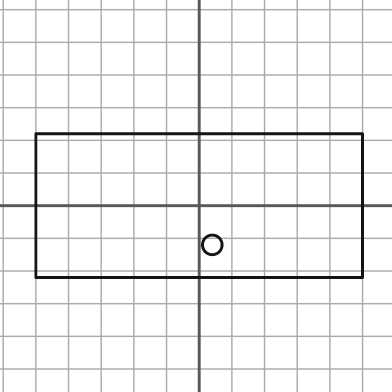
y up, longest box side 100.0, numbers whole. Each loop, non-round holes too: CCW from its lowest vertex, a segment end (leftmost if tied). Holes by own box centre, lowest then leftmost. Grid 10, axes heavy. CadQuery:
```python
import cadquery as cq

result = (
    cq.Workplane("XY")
    .moveTo(-50.0, -22.0)
    .lineTo(50.0, -22.0)
    .lineTo(50.0, 22.0)
    .lineTo(-50.0, 22.0)
    .close()
    .moveTo(4.0, -12.0)
    .circle(3.0)
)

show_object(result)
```